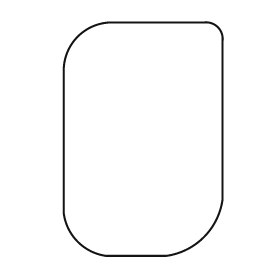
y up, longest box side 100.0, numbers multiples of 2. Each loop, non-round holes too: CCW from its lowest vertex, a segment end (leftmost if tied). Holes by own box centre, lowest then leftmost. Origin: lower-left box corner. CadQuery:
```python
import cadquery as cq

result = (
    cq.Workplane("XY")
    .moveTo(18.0, 0.0)
    .lineTo(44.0, 0.0)
    .threePointArc((60.0, 8.0), (68.0, 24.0))
    .lineTo(68.0, 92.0)
    .threePointArc((66.0, 98.0), (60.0, 100.0))
    .lineTo(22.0, 100.0)
    .threePointArc((6.0, 94.0), (0.0, 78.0))
    .lineTo(0.0, 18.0)
    .threePointArc((6.0, 6.0), (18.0, 0.0))
    .close()
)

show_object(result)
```